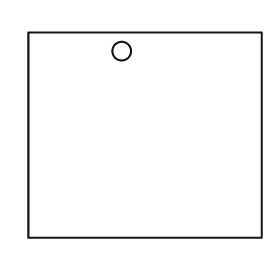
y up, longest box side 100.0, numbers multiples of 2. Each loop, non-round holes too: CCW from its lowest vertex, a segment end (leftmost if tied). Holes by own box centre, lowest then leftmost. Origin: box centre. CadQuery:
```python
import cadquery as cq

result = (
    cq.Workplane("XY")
    .moveTo(-50.0, -44.0)
    .lineTo(50.0, -44.0)
    .lineTo(50.0, 44.0)
    .lineTo(-50.0, 44.0)
    .close()
    .moveTo(-10.0, 36.0)
    .circle(4.0)
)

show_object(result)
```